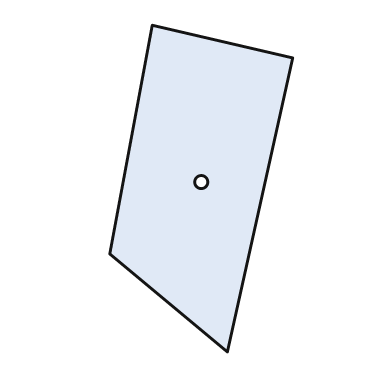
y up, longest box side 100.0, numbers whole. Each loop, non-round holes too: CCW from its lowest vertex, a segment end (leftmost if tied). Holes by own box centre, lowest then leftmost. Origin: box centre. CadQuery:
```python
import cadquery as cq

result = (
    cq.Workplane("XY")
    .moveTo(8.0, -50.0)
    .lineTo(28.0, 40.0)
    .lineTo(-15.0, 50.0)
    .lineTo(-28.0, -20.0)
    .close()
    .moveTo(0.0, 2.0)
    .circle(2.0)
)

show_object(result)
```